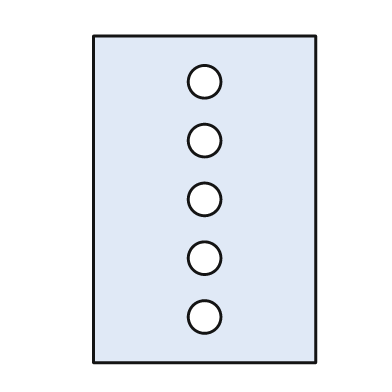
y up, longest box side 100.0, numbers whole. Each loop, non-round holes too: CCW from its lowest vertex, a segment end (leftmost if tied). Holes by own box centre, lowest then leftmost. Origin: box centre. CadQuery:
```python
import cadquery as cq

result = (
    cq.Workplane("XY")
    .moveTo(-34.0, -50.0)
    .lineTo(34.0, -50.0)
    .lineTo(34.0, 50.0)
    .lineTo(-34.0, 50.0)
    .close()
    .moveTo(0.0, -36.0)
    .circle(5.0)
    .moveTo(0.0, -18.0)
    .circle(5.0)
    .moveTo(0.0, 0.0)
    .circle(5.0)
    .moveTo(0.0, 18.0)
    .circle(5.0)
    .moveTo(0.0, 36.0)
    .circle(5.0)
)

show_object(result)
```